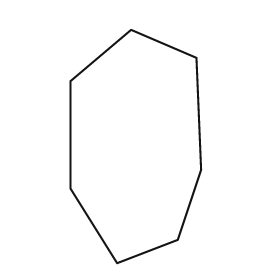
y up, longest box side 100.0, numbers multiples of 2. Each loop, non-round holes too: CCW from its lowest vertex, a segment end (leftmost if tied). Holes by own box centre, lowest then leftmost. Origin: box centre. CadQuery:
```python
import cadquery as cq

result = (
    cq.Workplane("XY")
    .moveTo(-8.0, -50.0)
    .lineTo(18.0, -40.0)
    .lineTo(28.0, -10.0)
    .lineTo(26.0, 38.0)
    .lineTo(-2.0, 50.0)
    .lineTo(-28.0, 28.0)
    .lineTo(-28.0, -18.0)
    .close()
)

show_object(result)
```